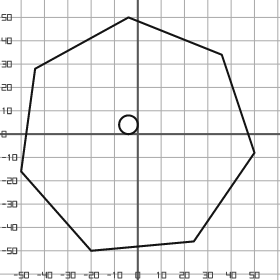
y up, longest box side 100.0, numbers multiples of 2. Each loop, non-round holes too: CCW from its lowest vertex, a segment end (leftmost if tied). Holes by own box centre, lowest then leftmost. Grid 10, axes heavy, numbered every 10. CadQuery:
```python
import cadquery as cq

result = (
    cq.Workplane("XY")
    .moveTo(-20.0, -50.0)
    .lineTo(24.0, -46.0)
    .lineTo(50.0, -8.0)
    .lineTo(36.0, 34.0)
    .lineTo(-4.0, 50.0)
    .lineTo(-44.0, 28.0)
    .lineTo(-50.0, -16.0)
    .close()
    .moveTo(-4.0, 4.0)
    .circle(4.0)
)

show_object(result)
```